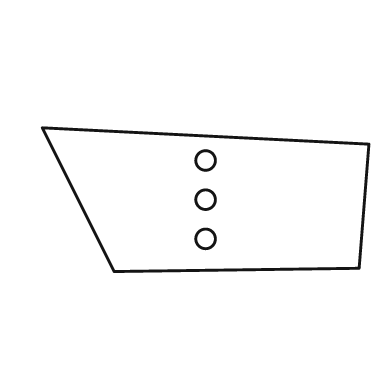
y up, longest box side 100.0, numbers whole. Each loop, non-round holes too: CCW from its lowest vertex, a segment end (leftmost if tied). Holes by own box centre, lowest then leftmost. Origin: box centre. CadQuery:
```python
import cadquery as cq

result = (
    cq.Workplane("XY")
    .moveTo(-28.0, -22.0)
    .lineTo(47.0, -21.0)
    .lineTo(50.0, 17.0)
    .lineTo(-50.0, 22.0)
    .close()
    .moveTo(0.0, -12.0)
    .circle(3.0)
    .moveTo(0.0, 0.0)
    .circle(3.0)
    .moveTo(0.0, 12.0)
    .circle(3.0)
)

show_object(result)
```